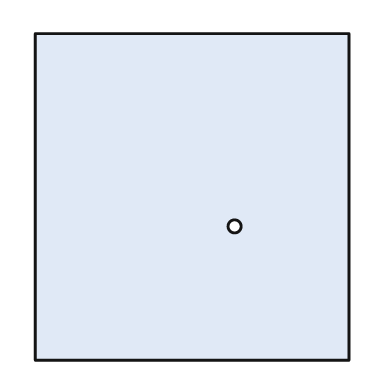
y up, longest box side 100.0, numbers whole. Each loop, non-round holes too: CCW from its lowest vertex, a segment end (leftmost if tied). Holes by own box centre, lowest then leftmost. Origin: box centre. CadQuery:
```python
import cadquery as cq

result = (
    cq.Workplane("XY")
    .moveTo(-48.0, -50.0)
    .lineTo(48.0, -50.0)
    .lineTo(48.0, 50.0)
    .lineTo(-48.0, 50.0)
    .close()
    .moveTo(13.0, -9.0)
    .circle(2.0)
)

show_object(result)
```